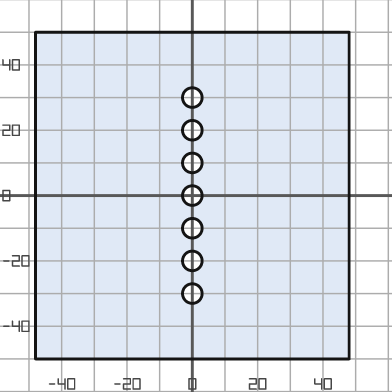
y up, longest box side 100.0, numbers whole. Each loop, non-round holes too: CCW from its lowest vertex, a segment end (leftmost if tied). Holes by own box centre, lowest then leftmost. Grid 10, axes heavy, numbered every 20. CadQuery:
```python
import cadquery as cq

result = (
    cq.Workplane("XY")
    .moveTo(-48.0, -50.0)
    .lineTo(48.0, -50.0)
    .lineTo(48.0, 50.0)
    .lineTo(-48.0, 50.0)
    .close()
    .moveTo(0.0, -30.0)
    .circle(3.0)
    .moveTo(0.0, -20.0)
    .circle(3.0)
    .moveTo(0.0, -10.0)
    .circle(3.0)
    .moveTo(0.0, 0.0)
    .circle(3.0)
    .moveTo(0.0, 10.0)
    .circle(3.0)
    .moveTo(0.0, 20.0)
    .circle(3.0)
    .moveTo(0.0, 30.0)
    .circle(3.0)
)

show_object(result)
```